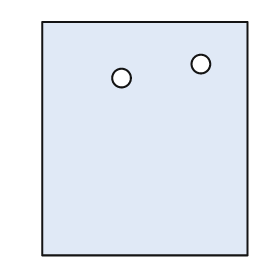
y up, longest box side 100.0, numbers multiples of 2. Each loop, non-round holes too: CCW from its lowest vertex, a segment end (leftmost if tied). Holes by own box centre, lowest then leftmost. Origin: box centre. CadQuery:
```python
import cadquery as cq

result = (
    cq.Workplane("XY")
    .moveTo(-44.0, -50.0)
    .lineTo(44.0, -50.0)
    .lineTo(44.0, 50.0)
    .lineTo(-44.0, 50.0)
    .close()
    .moveTo(-10.0, 26.0)
    .circle(4.0)
    .moveTo(24.0, 32.0)
    .circle(4.0)
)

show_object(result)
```